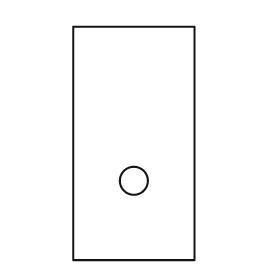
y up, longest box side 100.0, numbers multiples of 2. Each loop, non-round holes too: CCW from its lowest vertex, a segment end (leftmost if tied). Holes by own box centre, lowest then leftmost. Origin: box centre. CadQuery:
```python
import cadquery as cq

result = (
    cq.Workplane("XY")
    .moveTo(-26.0, -50.0)
    .lineTo(26.0, -50.0)
    .lineTo(26.0, 50.0)
    .lineTo(-26.0, 50.0)
    .close()
    .moveTo(0.0, -16.0)
    .circle(6.0)
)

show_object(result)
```